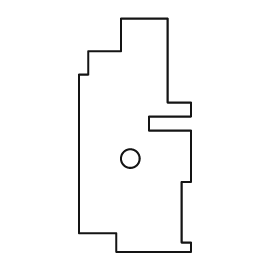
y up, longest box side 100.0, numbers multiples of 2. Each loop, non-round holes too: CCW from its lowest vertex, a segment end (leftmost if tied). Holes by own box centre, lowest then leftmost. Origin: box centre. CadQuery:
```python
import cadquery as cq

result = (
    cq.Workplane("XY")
    .moveTo(-8.0, -50.0)
    .lineTo(24.0, -50.0)
    .lineTo(24.0, -46.0)
    .lineTo(20.0, -46.0)
    .lineTo(20.0, -20.0)
    .lineTo(24.0, -20.0)
    .lineTo(24.0, 2.0)
    .lineTo(6.0, 2.0)
    .lineTo(6.0, 8.0)
    .lineTo(24.0, 8.0)
    .lineTo(24.0, 14.0)
    .lineTo(14.0, 14.0)
    .lineTo(14.0, 50.0)
    .lineTo(-6.0, 50.0)
    .lineTo(-6.0, 36.0)
    .lineTo(-20.0, 36.0)
    .lineTo(-20.0, 26.0)
    .lineTo(-24.0, 26.0)
    .lineTo(-24.0, -42.0)
    .lineTo(-8.0, -42.0)
    .close()
    .moveTo(-2.0, -10.0)
    .circle(4.0)
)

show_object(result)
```